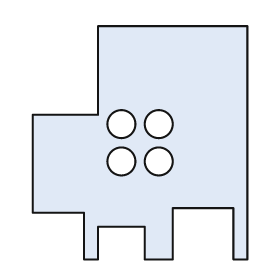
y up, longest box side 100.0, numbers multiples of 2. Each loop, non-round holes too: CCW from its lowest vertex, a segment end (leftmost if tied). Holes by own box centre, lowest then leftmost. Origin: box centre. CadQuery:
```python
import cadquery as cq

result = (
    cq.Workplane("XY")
    .moveTo(-24.0, -50.0)
    .lineTo(-18.0, -50.0)
    .lineTo(-18.0, -36.0)
    .lineTo(2.0, -36.0)
    .lineTo(2.0, -50.0)
    .lineTo(14.0, -50.0)
    .lineTo(14.0, -28.0)
    .lineTo(40.0, -28.0)
    .lineTo(40.0, -50.0)
    .lineTo(46.0, -50.0)
    .lineTo(46.0, 50.0)
    .lineTo(-18.0, 50.0)
    .lineTo(-18.0, 12.0)
    .lineTo(-46.0, 12.0)
    .lineTo(-46.0, -30.0)
    .lineTo(-24.0, -30.0)
    .close()
    .moveTo(-8.0, -8.0)
    .circle(6.0)
    .moveTo(8.0, -8.0)
    .circle(6.0)
    .moveTo(-8.0, 8.0)
    .circle(6.0)
    .moveTo(8.0, 8.0)
    .circle(6.0)
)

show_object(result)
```